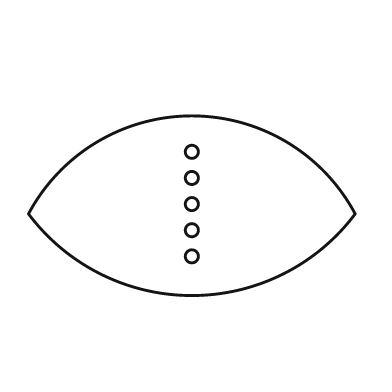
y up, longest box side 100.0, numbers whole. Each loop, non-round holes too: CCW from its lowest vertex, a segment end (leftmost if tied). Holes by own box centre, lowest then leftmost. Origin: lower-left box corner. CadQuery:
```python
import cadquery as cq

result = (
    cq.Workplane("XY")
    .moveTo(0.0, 25.0)
    .threePointArc((50.0, 0.0), (100.0, 25.0))
    .threePointArc((50.0, 55.0), (0.0, 25.0))
    .close()
    .moveTo(50.0, 12.0)
    .circle(2.0)
    .moveTo(50.0, 20.0)
    .circle(2.0)
    .moveTo(50.0, 28.0)
    .circle(2.0)
    .moveTo(50.0, 36.0)
    .circle(2.0)
    .moveTo(50.0, 44.0)
    .circle(2.0)
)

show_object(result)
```